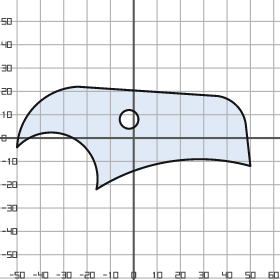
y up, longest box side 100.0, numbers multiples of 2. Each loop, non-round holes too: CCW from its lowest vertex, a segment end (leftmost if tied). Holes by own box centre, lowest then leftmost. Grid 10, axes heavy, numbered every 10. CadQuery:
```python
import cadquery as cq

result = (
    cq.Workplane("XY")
    .moveTo(-16.0, -22.0)
    .threePointArc((16.0, -10.0), (50.0, -12.0))
    .lineTo(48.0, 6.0)
    .threePointArc((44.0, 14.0), (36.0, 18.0))
    .lineTo(-24.0, 22.0)
    .threePointArc((-42.0, 14.0), (-50.0, -4.0))
    .threePointArc((-26.0, 0.0), (-16.0, -22.0))
    .close()
    .moveTo(-2.0, 8.0)
    .circle(4.0)
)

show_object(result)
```